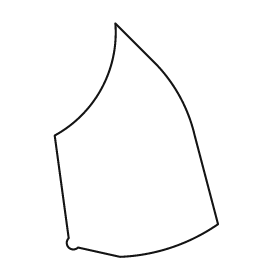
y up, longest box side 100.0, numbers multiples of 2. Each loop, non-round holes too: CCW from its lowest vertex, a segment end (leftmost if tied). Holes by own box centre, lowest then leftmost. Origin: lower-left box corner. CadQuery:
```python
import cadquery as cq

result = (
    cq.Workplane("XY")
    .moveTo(28.0, 0.0)
    .threePointArc((50.0, 4.0), (70.0, 14.0))
    .lineTo(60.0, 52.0)
    .threePointArc((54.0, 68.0), (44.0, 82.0))
    .lineTo(26.0, 100.0)
    .threePointArc((20.0, 72.0), (0.0, 52.0))
    .lineTo(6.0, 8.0)
    .threePointArc((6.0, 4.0), (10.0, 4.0))
    .close()
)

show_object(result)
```